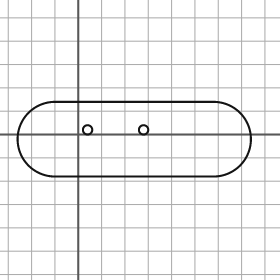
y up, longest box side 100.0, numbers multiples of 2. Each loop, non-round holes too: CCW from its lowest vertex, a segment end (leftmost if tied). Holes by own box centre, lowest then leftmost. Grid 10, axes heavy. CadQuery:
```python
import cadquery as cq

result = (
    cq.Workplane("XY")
    .moveTo(-10.0, -18.0)
    .lineTo(58.0, -18.0)
    .threePointArc((74.0, -2.0), (58.0, 14.0))
    .lineTo(-10.0, 14.0)
    .threePointArc((-26.0, -2.0), (-10.0, -18.0))
    .close()
    .moveTo(4.0, 2.0)
    .circle(2.0)
    .moveTo(28.0, 2.0)
    .circle(2.0)
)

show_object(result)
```